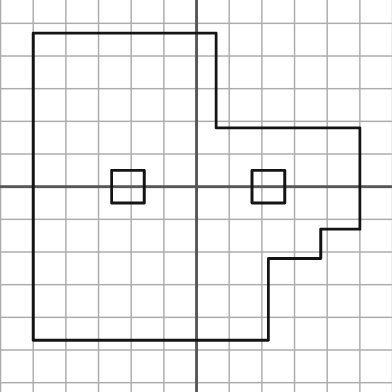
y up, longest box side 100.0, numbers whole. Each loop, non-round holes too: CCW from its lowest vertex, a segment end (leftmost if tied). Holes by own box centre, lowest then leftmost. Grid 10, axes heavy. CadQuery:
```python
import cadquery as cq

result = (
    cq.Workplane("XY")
    .moveTo(-50.0, -47.0)
    .lineTo(22.0, -47.0)
    .lineTo(22.0, -22.0)
    .lineTo(38.0, -22.0)
    .lineTo(38.0, -13.0)
    .lineTo(50.0, -13.0)
    .lineTo(50.0, 18.0)
    .lineTo(6.0, 18.0)
    .lineTo(6.0, 47.0)
    .lineTo(-50.0, 47.0)
    .close()
    .moveTo(-26.0, -5.0)
    .lineTo(-16.0, -5.0)
    .lineTo(-16.0, 5.0)
    .lineTo(-26.0, 5.0)
    .close()
    .moveTo(17.0, -5.0)
    .lineTo(27.0, -5.0)
    .lineTo(27.0, 5.0)
    .lineTo(17.0, 5.0)
    .close()
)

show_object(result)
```